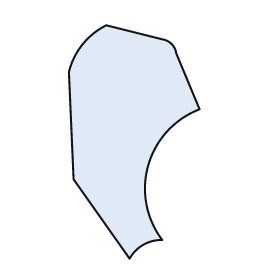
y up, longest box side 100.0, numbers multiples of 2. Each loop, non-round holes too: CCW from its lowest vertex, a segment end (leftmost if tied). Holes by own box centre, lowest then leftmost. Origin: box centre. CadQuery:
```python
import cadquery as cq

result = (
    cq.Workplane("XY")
    .moveTo(-2.0, -50.0)
    .threePointArc((4.0, -44.0), (12.0, -42.0))
    .threePointArc((6.0, -10.0), (28.0, 14.0))
    .lineTo(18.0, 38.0)
    .threePointArc((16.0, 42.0), (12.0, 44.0))
    .lineTo(-12.0, 50.0)
    .threePointArc((-22.0, 42.0), (-28.0, 30.0))
    .lineTo(-26.0, -16.0)
    .close()
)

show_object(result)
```